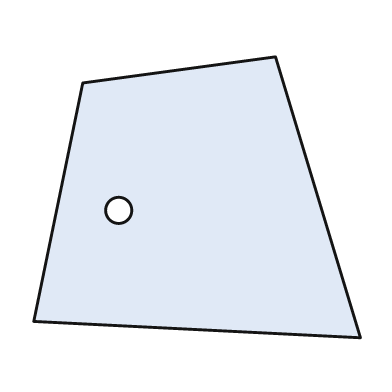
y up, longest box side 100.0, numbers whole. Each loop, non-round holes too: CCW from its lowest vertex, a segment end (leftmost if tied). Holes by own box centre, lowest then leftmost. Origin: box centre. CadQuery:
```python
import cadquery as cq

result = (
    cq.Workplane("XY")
    .moveTo(50.0, -43.0)
    .lineTo(24.0, 43.0)
    .lineTo(-35.0, 35.0)
    .lineTo(-50.0, -38.0)
    .close()
    .moveTo(-24.0, -4.0)
    .circle(4.0)
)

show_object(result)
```